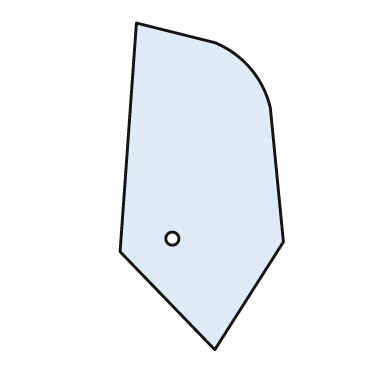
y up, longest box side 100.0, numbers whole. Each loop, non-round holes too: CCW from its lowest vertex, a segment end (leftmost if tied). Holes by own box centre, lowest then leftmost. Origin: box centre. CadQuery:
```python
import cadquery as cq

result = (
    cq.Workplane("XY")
    .moveTo(4.0, -50.0)
    .lineTo(25.0, -17.0)
    .lineTo(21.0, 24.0)
    .threePointArc((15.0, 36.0), (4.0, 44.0))
    .lineTo(-20.0, 50.0)
    .lineTo(-25.0, -20.0)
    .close()
    .moveTo(-9.0, -16.0)
    .circle(2.0)
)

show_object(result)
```